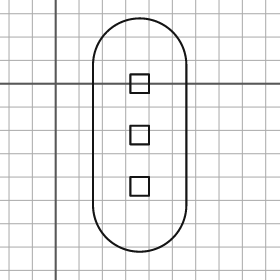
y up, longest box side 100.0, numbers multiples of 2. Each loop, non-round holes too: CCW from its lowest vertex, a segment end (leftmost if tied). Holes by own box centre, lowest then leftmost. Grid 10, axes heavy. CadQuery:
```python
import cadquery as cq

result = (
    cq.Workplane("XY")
    .moveTo(16.0, -52.0)
    .threePointArc((36.0, -72.0), (56.0, -52.0))
    .lineTo(56.0, 8.0)
    .threePointArc((36.0, 28.0), (16.0, 8.0))
    .close()
    .moveTo(32.0, -48.0)
    .lineTo(40.0, -48.0)
    .lineTo(40.0, -40.0)
    .lineTo(32.0, -40.0)
    .close()
    .moveTo(32.0, -26.0)
    .lineTo(40.0, -26.0)
    .lineTo(40.0, -18.0)
    .lineTo(32.0, -18.0)
    .close()
    .moveTo(32.0, -4.0)
    .lineTo(40.0, -4.0)
    .lineTo(40.0, 4.0)
    .lineTo(32.0, 4.0)
    .close()
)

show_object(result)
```